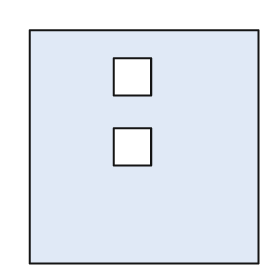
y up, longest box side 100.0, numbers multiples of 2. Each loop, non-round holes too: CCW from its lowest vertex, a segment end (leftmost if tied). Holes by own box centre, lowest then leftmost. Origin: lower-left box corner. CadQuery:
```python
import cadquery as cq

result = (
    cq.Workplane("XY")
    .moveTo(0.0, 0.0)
    .lineTo(98.0, 0.0)
    .lineTo(98.0, 100.0)
    .lineTo(0.0, 100.0)
    .close()
    .moveTo(36.0, 42.0)
    .lineTo(52.0, 42.0)
    .lineTo(52.0, 58.0)
    .lineTo(36.0, 58.0)
    .close()
    .moveTo(36.0, 72.0)
    .lineTo(52.0, 72.0)
    .lineTo(52.0, 88.0)
    .lineTo(36.0, 88.0)
    .close()
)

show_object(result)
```